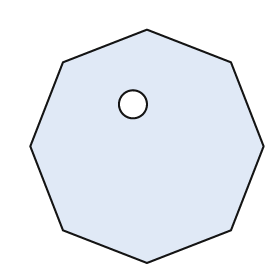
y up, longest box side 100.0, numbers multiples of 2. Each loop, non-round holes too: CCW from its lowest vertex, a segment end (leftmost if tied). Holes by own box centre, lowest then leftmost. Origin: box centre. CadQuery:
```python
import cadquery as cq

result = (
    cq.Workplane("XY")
    .moveTo(0.0, -50.0)
    .lineTo(36.0, -36.0)
    .lineTo(50.0, 0.0)
    .lineTo(36.0, 36.0)
    .lineTo(0.0, 50.0)
    .lineTo(-36.0, 36.0)
    .lineTo(-50.0, 0.0)
    .lineTo(-36.0, -36.0)
    .close()
    .moveTo(-6.0, 18.0)
    .circle(6.0)
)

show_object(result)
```